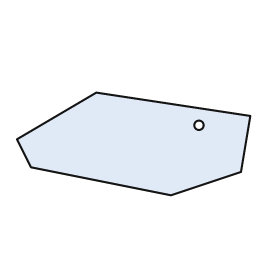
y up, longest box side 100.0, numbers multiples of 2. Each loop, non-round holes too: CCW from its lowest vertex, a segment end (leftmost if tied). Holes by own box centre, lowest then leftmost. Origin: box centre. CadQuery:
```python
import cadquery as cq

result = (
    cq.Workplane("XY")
    .moveTo(16.0, -22.0)
    .lineTo(46.0, -12.0)
    .lineTo(50.0, 12.0)
    .lineTo(-16.0, 22.0)
    .lineTo(-50.0, 2.0)
    .lineTo(-44.0, -10.0)
    .close()
    .moveTo(28.0, 8.0)
    .circle(2.0)
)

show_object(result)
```